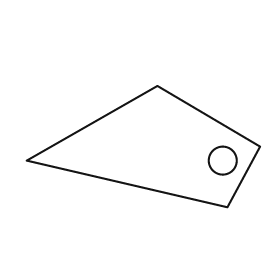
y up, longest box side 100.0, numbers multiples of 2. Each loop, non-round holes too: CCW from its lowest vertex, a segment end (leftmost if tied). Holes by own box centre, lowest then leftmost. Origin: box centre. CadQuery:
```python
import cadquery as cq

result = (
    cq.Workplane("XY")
    .moveTo(36.0, -26.0)
    .lineTo(50.0, 0.0)
    .lineTo(6.0, 26.0)
    .lineTo(-50.0, -6.0)
    .close()
    .moveTo(34.0, -6.0)
    .circle(6.0)
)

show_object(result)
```